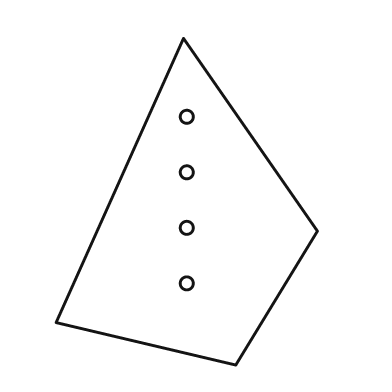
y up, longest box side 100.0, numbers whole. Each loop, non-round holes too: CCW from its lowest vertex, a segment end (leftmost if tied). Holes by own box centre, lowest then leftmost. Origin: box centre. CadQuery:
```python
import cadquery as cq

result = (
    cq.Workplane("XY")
    .moveTo(15.0, -50.0)
    .lineTo(40.0, -9.0)
    .lineTo(-1.0, 50.0)
    .lineTo(-40.0, -37.0)
    .close()
    .moveTo(0.0, -25.0)
    .circle(2.0)
    .moveTo(0.0, -8.0)
    .circle(2.0)
    .moveTo(0.0, 9.0)
    .circle(2.0)
    .moveTo(0.0, 26.0)
    .circle(2.0)
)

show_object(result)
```